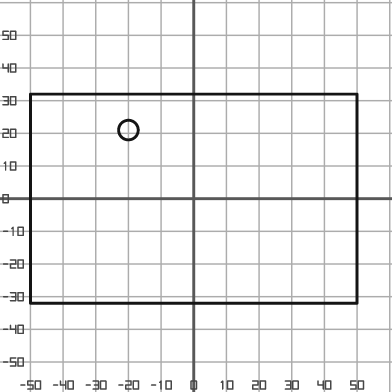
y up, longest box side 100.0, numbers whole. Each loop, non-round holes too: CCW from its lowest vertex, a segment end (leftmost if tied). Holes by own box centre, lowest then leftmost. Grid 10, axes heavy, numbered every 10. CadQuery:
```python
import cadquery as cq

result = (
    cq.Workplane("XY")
    .moveTo(-50.0, -32.0)
    .lineTo(50.0, -32.0)
    .lineTo(50.0, 32.0)
    .lineTo(-50.0, 32.0)
    .close()
    .moveTo(-20.0, 21.0)
    .circle(3.0)
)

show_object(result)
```